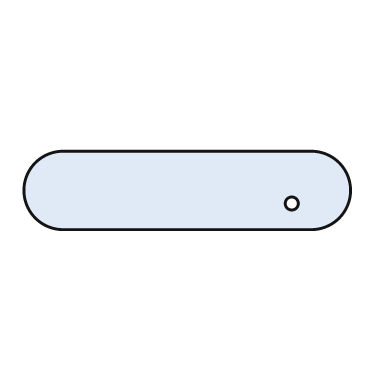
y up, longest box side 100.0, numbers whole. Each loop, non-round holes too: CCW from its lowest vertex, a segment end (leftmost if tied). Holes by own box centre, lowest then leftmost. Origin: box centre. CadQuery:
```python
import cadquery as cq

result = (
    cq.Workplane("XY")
    .moveTo(-38.0, -12.0)
    .lineTo(38.0, -12.0)
    .threePointArc((50.0, 0.0), (38.0, 12.0))
    .lineTo(-38.0, 12.0)
    .threePointArc((-50.0, 0.0), (-38.0, -12.0))
    .close()
    .moveTo(32.0, -4.0)
    .circle(2.0)
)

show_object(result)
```